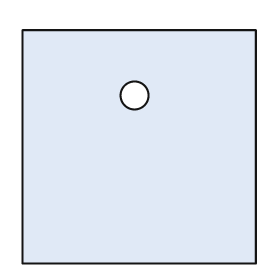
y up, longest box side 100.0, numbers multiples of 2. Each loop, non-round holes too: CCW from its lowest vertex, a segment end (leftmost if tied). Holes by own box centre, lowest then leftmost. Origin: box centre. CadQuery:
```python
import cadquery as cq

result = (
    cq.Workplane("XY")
    .moveTo(-50.0, -50.0)
    .lineTo(50.0, -50.0)
    .lineTo(50.0, 50.0)
    .lineTo(-50.0, 50.0)
    .close()
    .moveTo(-2.0, 22.0)
    .circle(6.0)
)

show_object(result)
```